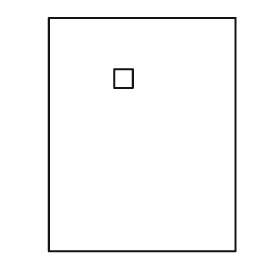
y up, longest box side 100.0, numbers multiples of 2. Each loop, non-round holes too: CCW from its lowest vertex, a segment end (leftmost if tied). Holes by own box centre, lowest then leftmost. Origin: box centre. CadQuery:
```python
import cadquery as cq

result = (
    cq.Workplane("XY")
    .moveTo(-40.0, -50.0)
    .lineTo(40.0, -50.0)
    .lineTo(40.0, 50.0)
    .lineTo(-40.0, 50.0)
    .close()
    .moveTo(-12.0, 20.0)
    .lineTo(-4.0, 20.0)
    .lineTo(-4.0, 28.0)
    .lineTo(-12.0, 28.0)
    .close()
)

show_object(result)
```